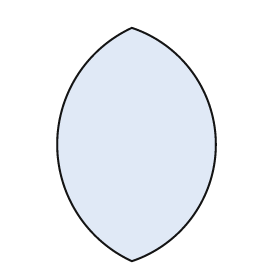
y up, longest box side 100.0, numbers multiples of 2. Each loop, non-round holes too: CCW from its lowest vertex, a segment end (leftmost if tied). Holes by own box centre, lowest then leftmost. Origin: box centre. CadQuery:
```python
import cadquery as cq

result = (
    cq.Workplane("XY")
    .moveTo(-2.0, -50.0)
    .threePointArc((34.0, 0.0), (-2.0, 50.0))
    .threePointArc((-34.0, 0.0), (-2.0, -50.0))
    .close()
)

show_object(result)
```